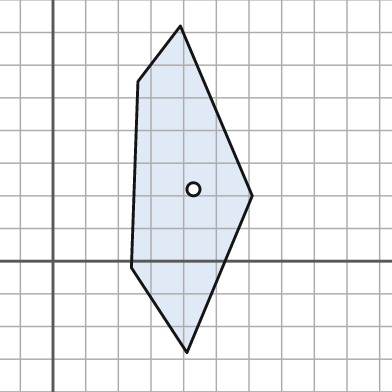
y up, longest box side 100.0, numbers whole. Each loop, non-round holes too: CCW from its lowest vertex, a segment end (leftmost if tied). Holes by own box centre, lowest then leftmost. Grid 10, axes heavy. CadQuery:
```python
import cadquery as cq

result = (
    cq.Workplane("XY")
    .moveTo(41.0, -28.0)
    .lineTo(61.0, 20.0)
    .lineTo(39.0, 72.0)
    .lineTo(26.0, 55.0)
    .lineTo(24.0, -2.0)
    .close()
    .moveTo(43.0, 22.0)
    .circle(2.0)
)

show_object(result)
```